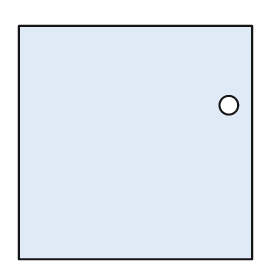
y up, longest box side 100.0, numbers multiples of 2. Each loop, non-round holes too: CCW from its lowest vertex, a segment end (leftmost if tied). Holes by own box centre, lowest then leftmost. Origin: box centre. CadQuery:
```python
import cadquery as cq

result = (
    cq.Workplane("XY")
    .moveTo(-50.0, -50.0)
    .lineTo(50.0, -50.0)
    .lineTo(50.0, 50.0)
    .lineTo(-50.0, 50.0)
    .close()
    .moveTo(40.0, 16.0)
    .circle(4.0)
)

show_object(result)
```